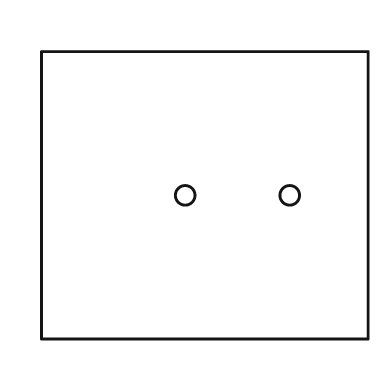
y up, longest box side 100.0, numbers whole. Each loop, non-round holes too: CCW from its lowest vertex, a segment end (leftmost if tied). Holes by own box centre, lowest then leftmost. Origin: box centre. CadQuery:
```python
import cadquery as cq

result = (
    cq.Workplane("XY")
    .moveTo(-50.0, -44.0)
    .lineTo(50.0, -44.0)
    .lineTo(50.0, 44.0)
    .lineTo(-50.0, 44.0)
    .close()
    .moveTo(-6.0, 0.0)
    .circle(3.0)
    .moveTo(26.0, 0.0)
    .circle(3.0)
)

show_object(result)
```